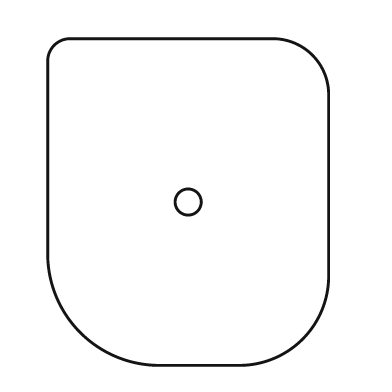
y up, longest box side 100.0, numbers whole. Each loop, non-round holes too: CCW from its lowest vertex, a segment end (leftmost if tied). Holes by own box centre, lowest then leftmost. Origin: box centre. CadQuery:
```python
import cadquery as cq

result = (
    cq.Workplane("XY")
    .moveTo(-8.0, -50.0)
    .lineTo(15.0, -50.0)
    .threePointArc((35.0, -42.0), (43.0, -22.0))
    .lineTo(43.0, 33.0)
    .threePointArc((38.0, 45.0), (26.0, 50.0))
    .lineTo(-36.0, 50.0)
    .threePointArc((-41.0, 48.0), (-43.0, 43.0))
    .lineTo(-43.0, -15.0)
    .threePointArc((-33.0, -40.0), (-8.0, -50.0))
    .close()
    .moveTo(0.0, 0.0)
    .circle(4.0)
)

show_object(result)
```